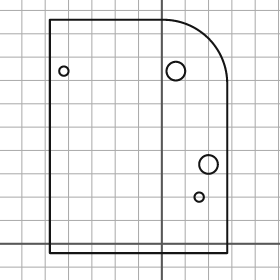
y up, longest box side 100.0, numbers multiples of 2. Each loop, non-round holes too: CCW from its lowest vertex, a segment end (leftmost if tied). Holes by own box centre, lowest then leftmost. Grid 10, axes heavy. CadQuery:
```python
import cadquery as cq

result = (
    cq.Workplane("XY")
    .moveTo(-48.0, -4.0)
    .lineTo(28.0, -4.0)
    .lineTo(28.0, 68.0)
    .threePointArc((20.0, 88.0), (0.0, 96.0))
    .lineTo(-48.0, 96.0)
    .close()
    .moveTo(16.0, 20.0)
    .circle(2.0)
    .moveTo(20.0, 34.0)
    .circle(4.0)
    .moveTo(-42.0, 74.0)
    .circle(2.0)
    .moveTo(6.0, 74.0)
    .circle(4.0)
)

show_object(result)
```